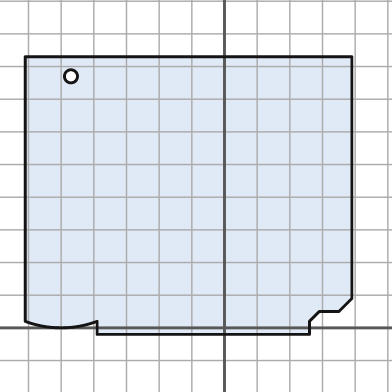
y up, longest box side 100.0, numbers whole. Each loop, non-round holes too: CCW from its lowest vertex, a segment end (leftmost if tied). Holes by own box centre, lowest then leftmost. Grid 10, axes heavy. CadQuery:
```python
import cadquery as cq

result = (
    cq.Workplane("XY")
    .moveTo(-39.0, -2.0)
    .lineTo(26.0, -2.0)
    .lineTo(26.0, 2.0)
    .lineTo(29.0, 5.0)
    .lineTo(35.0, 5.0)
    .lineTo(39.0, 9.0)
    .lineTo(39.0, 83.0)
    .lineTo(-61.0, 83.0)
    .lineTo(-61.0, 2.0)
    .threePointArc((-50.0, 0.0), (-39.0, 2.0))
    .close()
    .moveTo(-47.0, 77.0)
    .circle(2.0)
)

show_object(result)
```